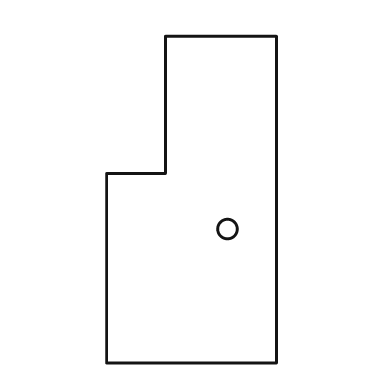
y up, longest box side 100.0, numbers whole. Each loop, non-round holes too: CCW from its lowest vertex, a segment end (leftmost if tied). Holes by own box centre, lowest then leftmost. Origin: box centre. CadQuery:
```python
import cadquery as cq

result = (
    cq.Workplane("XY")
    .moveTo(-26.0, -50.0)
    .lineTo(26.0, -50.0)
    .lineTo(26.0, 50.0)
    .lineTo(-8.0, 50.0)
    .lineTo(-8.0, 8.0)
    .lineTo(-26.0, 8.0)
    .close()
    .moveTo(11.0, -9.0)
    .circle(3.0)
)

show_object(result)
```